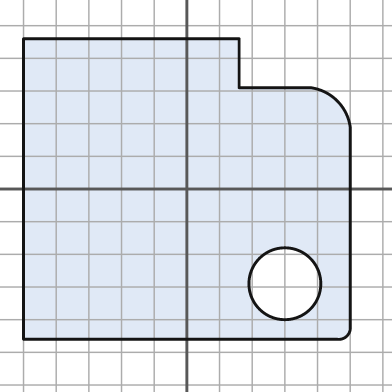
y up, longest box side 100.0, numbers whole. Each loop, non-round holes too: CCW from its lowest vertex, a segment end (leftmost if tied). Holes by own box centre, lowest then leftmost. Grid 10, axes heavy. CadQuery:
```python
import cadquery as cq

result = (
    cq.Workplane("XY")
    .moveTo(-50.0, -46.0)
    .lineTo(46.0, -46.0)
    .threePointArc((49.0, -45.0), (50.0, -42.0))
    .lineTo(50.0, 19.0)
    .threePointArc((46.0, 27.0), (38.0, 31.0))
    .lineTo(16.0, 31.0)
    .lineTo(16.0, 46.0)
    .lineTo(-50.0, 46.0)
    .close()
    .moveTo(30.0, -29.0)
    .circle(11.0)
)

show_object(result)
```